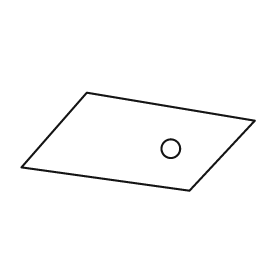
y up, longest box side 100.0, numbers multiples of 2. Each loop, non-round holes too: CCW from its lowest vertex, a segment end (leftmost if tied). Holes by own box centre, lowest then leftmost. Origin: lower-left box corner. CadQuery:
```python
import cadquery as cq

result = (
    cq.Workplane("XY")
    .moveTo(72.0, 0.0)
    .lineTo(100.0, 30.0)
    .lineTo(28.0, 42.0)
    .lineTo(0.0, 10.0)
    .close()
    .moveTo(64.0, 18.0)
    .circle(4.0)
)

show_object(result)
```